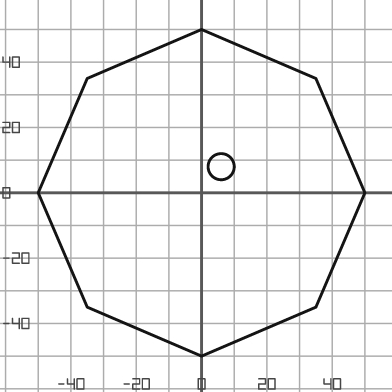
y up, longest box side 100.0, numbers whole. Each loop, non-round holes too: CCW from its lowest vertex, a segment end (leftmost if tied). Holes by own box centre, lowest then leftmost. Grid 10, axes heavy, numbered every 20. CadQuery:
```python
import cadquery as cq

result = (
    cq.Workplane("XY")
    .moveTo(0.0, -50.0)
    .lineTo(35.0, -35.0)
    .lineTo(50.0, 0.0)
    .lineTo(35.0, 35.0)
    .lineTo(0.0, 50.0)
    .lineTo(-35.0, 35.0)
    .lineTo(-50.0, 0.0)
    .lineTo(-35.0, -35.0)
    .close()
    .moveTo(6.0, 8.0)
    .circle(4.0)
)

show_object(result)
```